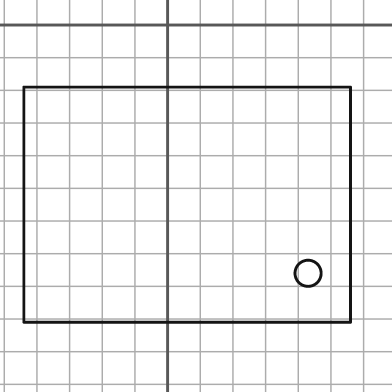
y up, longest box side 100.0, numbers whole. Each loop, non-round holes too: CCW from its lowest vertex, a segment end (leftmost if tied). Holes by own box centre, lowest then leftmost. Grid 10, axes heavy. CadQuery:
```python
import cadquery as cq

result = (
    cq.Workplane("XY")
    .moveTo(-44.0, -91.0)
    .lineTo(56.0, -91.0)
    .lineTo(56.0, -19.0)
    .lineTo(-44.0, -19.0)
    .close()
    .moveTo(43.0, -76.0)
    .circle(4.0)
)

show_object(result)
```